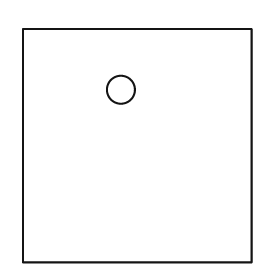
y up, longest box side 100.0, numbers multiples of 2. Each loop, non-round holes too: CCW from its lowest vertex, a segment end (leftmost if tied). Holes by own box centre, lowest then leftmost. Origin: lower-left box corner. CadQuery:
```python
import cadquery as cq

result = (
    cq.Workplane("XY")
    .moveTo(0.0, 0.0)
    .lineTo(98.0, 0.0)
    .lineTo(98.0, 100.0)
    .lineTo(0.0, 100.0)
    .close()
    .moveTo(42.0, 74.0)
    .circle(6.0)
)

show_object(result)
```